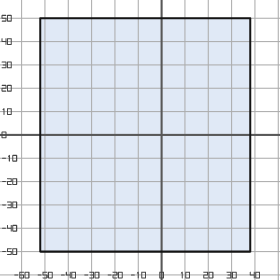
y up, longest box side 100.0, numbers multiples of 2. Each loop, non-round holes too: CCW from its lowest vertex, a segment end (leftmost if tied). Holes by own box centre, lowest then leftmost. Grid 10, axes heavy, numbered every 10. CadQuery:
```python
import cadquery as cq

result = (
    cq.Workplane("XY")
    .moveTo(-52.0, -50.0)
    .lineTo(38.0, -50.0)
    .lineTo(38.0, 50.0)
    .lineTo(-52.0, 50.0)
    .close()
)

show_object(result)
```